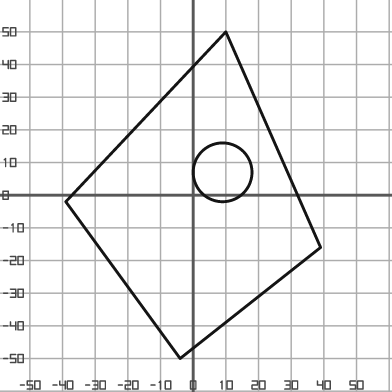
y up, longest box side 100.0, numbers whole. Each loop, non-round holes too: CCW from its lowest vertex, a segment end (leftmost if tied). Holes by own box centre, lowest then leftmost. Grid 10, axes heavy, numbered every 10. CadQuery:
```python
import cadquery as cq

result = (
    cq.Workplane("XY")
    .moveTo(-4.0, -50.0)
    .lineTo(39.0, -16.0)
    .lineTo(10.0, 50.0)
    .lineTo(-39.0, -2.0)
    .close()
    .moveTo(9.0, 7.0)
    .circle(9.0)
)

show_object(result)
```